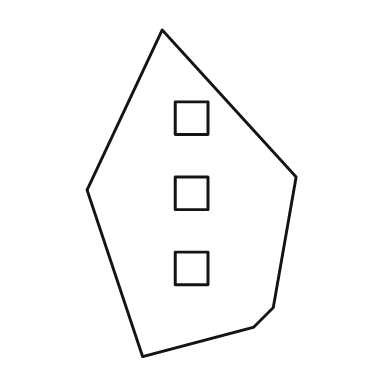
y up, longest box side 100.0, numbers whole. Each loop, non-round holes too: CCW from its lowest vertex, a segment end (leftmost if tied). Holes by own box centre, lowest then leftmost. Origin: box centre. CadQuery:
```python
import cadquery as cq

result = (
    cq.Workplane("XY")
    .moveTo(-15.0, -50.0)
    .lineTo(19.0, -41.0)
    .lineTo(25.0, -35.0)
    .lineTo(32.0, 5.0)
    .lineTo(-9.0, 50.0)
    .lineTo(-32.0, 1.0)
    .close()
    .moveTo(-5.0, -28.0)
    .lineTo(5.0, -28.0)
    .lineTo(5.0, -18.0)
    .lineTo(-5.0, -18.0)
    .close()
    .moveTo(-5.0, -5.0)
    .lineTo(5.0, -5.0)
    .lineTo(5.0, 5.0)
    .lineTo(-5.0, 5.0)
    .close()
    .moveTo(-5.0, 18.0)
    .lineTo(5.0, 18.0)
    .lineTo(5.0, 28.0)
    .lineTo(-5.0, 28.0)
    .close()
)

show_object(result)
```